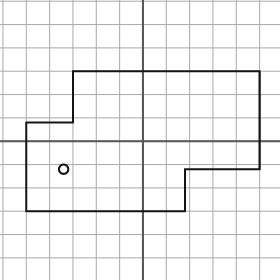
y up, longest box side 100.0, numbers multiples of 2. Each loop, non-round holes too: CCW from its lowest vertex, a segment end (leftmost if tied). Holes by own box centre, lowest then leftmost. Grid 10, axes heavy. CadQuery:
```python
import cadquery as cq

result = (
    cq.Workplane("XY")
    .moveTo(-50.0, -30.0)
    .lineTo(18.0, -30.0)
    .lineTo(18.0, -12.0)
    .lineTo(50.0, -12.0)
    .lineTo(50.0, 30.0)
    .lineTo(-30.0, 30.0)
    .lineTo(-30.0, 8.0)
    .lineTo(-50.0, 8.0)
    .close()
    .moveTo(-34.0, -12.0)
    .circle(2.0)
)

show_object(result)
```